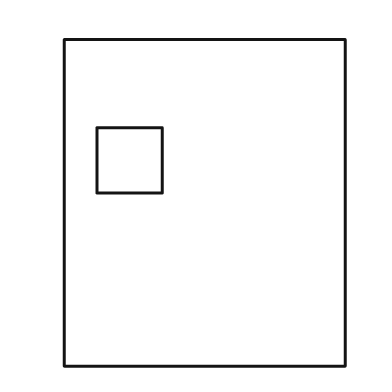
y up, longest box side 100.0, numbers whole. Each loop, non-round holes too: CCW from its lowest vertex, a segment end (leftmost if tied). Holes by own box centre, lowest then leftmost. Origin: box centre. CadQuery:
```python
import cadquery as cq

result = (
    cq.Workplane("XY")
    .moveTo(-43.0, -50.0)
    .lineTo(43.0, -50.0)
    .lineTo(43.0, 50.0)
    .lineTo(-43.0, 50.0)
    .close()
    .moveTo(-33.0, 3.0)
    .lineTo(-13.0, 3.0)
    .lineTo(-13.0, 23.0)
    .lineTo(-33.0, 23.0)
    .close()
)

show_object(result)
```